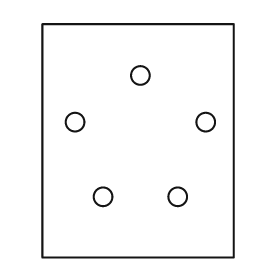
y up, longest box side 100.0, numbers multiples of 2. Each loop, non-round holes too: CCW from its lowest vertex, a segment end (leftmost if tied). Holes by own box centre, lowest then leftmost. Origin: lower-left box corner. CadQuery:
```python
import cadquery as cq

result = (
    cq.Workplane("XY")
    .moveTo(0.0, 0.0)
    .lineTo(82.0, 0.0)
    .lineTo(82.0, 100.0)
    .lineTo(0.0, 100.0)
    .close()
    .moveTo(26.0, 26.0)
    .circle(4.0)
    .moveTo(58.0, 26.0)
    .circle(4.0)
    .moveTo(14.0, 58.0)
    .circle(4.0)
    .moveTo(70.0, 58.0)
    .circle(4.0)
    .moveTo(42.0, 78.0)
    .circle(4.0)
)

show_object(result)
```